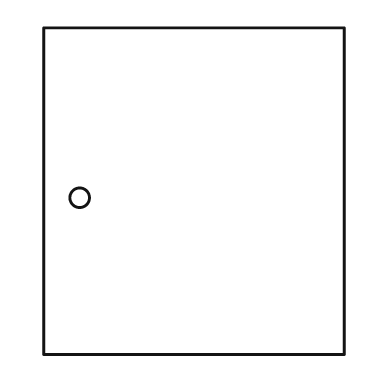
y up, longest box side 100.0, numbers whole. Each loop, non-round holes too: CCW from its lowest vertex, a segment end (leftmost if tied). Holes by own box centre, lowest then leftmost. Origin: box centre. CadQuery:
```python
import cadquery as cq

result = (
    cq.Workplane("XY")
    .moveTo(-46.0, -50.0)
    .lineTo(46.0, -50.0)
    .lineTo(46.0, 50.0)
    .lineTo(-46.0, 50.0)
    .close()
    .moveTo(-35.0, -2.0)
    .circle(3.0)
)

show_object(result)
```